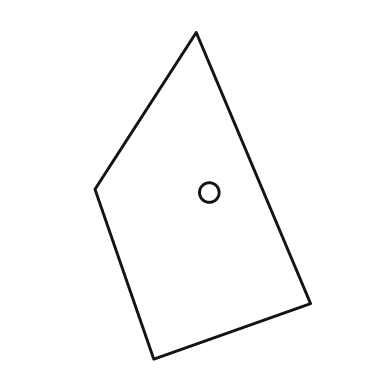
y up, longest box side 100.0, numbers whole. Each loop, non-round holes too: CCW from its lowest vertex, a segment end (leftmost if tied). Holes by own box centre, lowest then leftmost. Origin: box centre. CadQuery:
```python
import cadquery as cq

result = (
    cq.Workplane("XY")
    .moveTo(-15.0, -50.0)
    .lineTo(33.0, -33.0)
    .lineTo(-2.0, 50.0)
    .lineTo(-33.0, 2.0)
    .close()
    .moveTo(2.0, 1.0)
    .circle(3.0)
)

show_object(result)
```